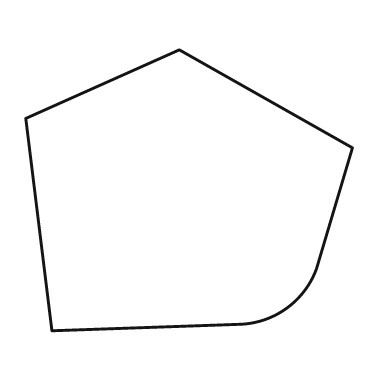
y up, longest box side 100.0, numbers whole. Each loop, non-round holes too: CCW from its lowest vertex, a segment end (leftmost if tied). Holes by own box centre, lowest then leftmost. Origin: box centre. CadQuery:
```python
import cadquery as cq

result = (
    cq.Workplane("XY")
    .moveTo(-42.0, -43.0)
    .lineTo(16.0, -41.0)
    .threePointArc((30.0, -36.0), (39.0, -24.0))
    .lineTo(50.0, 13.0)
    .lineTo(-3.0, 43.0)
    .lineTo(-50.0, 22.0)
    .close()
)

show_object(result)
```